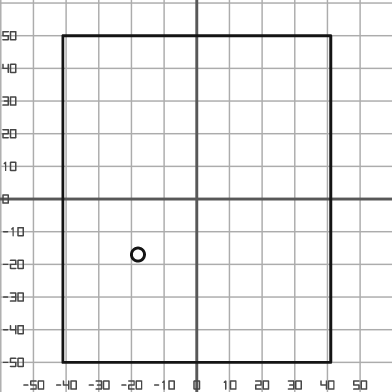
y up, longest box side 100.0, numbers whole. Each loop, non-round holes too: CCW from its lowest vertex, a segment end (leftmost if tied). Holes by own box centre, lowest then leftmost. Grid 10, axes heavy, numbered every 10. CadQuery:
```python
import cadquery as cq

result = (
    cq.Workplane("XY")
    .moveTo(-41.0, -50.0)
    .lineTo(41.0, -50.0)
    .lineTo(41.0, 50.0)
    .lineTo(-41.0, 50.0)
    .close()
    .moveTo(-18.0, -17.0)
    .circle(2.0)
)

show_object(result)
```